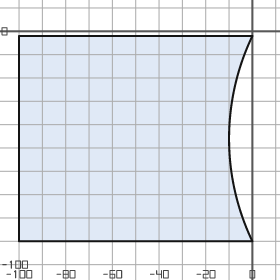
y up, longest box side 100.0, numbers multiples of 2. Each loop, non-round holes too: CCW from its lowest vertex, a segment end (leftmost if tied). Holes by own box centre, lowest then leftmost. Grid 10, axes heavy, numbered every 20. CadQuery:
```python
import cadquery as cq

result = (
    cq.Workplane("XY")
    .moveTo(-100.0, -90.0)
    .lineTo(0.0, -90.0)
    .threePointArc((-10.0, -46.0), (0.0, -2.0))
    .lineTo(-100.0, -2.0)
    .close()
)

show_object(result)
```